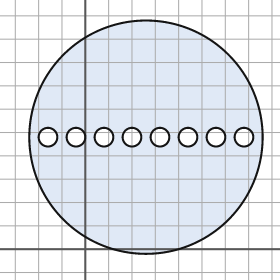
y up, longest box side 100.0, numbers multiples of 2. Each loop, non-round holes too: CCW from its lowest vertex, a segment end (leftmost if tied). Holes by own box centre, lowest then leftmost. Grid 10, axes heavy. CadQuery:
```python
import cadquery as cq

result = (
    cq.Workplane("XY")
    .moveTo(26.0, 48.0)
    .circle(50.0)
    .moveTo(-16.0, 48.0)
    .circle(4.0)
    .moveTo(-4.0, 48.0)
    .circle(4.0)
    .moveTo(8.0, 48.0)
    .circle(4.0)
    .moveTo(20.0, 48.0)
    .circle(4.0)
    .moveTo(32.0, 48.0)
    .circle(4.0)
    .moveTo(44.0, 48.0)
    .circle(4.0)
    .moveTo(56.0, 48.0)
    .circle(4.0)
    .moveTo(68.0, 48.0)
    .circle(4.0)
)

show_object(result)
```